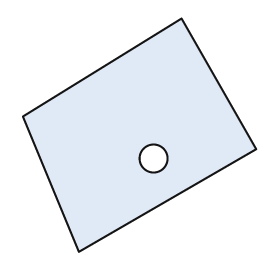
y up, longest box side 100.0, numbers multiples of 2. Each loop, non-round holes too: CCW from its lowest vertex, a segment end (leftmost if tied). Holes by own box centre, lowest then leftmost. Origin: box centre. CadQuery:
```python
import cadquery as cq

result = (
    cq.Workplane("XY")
    .moveTo(-26.0, -50.0)
    .lineTo(50.0, -6.0)
    .lineTo(18.0, 50.0)
    .lineTo(-50.0, 8.0)
    .close()
    .moveTo(6.0, -10.0)
    .circle(6.0)
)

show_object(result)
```